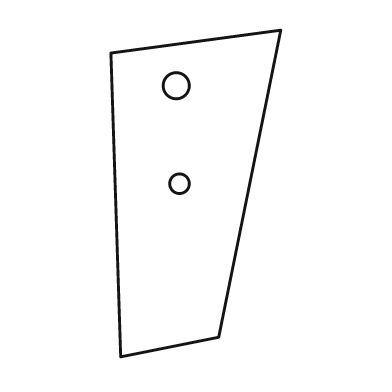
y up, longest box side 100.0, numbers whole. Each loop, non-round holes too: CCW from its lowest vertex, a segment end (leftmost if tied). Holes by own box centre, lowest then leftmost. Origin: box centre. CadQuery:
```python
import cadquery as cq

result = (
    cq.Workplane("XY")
    .moveTo(-23.0, -50.0)
    .lineTo(7.0, -44.0)
    .lineTo(26.0, 50.0)
    .lineTo(-26.0, 43.0)
    .close()
    .moveTo(-5.0, 3.0)
    .circle(3.0)
    .moveTo(-6.0, 33.0)
    .circle(4.0)
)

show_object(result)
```